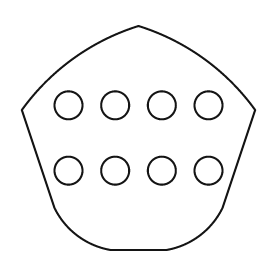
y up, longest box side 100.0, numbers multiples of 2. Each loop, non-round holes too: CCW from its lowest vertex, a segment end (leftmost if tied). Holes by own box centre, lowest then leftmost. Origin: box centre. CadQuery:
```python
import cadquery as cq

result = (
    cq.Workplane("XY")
    .moveTo(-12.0, -48.0)
    .lineTo(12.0, -48.0)
    .threePointArc((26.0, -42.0), (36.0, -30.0))
    .lineTo(50.0, 12.0)
    .threePointArc((28.0, 34.0), (0.0, 48.0))
    .threePointArc((-28.0, 34.0), (-50.0, 12.0))
    .lineTo(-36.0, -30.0)
    .threePointArc((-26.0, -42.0), (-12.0, -48.0))
    .close()
    .moveTo(-30.0, -14.0)
    .circle(6.0)
    .moveTo(-10.0, -14.0)
    .circle(6.0)
    .moveTo(10.0, -14.0)
    .circle(6.0)
    .moveTo(30.0, -14.0)
    .circle(6.0)
    .moveTo(-30.0, 14.0)
    .circle(6.0)
    .moveTo(-10.0, 14.0)
    .circle(6.0)
    .moveTo(10.0, 14.0)
    .circle(6.0)
    .moveTo(30.0, 14.0)
    .circle(6.0)
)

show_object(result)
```